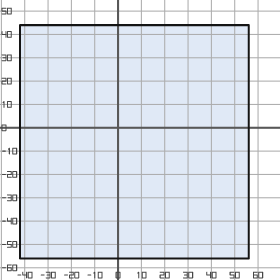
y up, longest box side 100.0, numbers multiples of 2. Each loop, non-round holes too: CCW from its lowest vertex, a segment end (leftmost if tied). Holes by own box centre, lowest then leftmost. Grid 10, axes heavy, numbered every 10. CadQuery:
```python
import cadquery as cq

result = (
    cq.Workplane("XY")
    .moveTo(-42.0, -56.0)
    .lineTo(56.0, -56.0)
    .lineTo(56.0, 44.0)
    .lineTo(-42.0, 44.0)
    .close()
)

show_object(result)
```